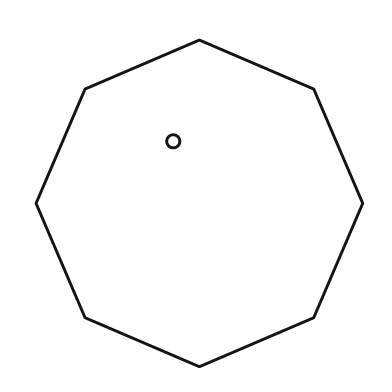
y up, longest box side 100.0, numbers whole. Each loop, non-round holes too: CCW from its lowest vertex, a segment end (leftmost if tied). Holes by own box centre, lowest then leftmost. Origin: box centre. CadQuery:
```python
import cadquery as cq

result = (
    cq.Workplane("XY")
    .moveTo(0.0, -50.0)
    .lineTo(35.0, -35.0)
    .lineTo(50.0, 0.0)
    .lineTo(35.0, 35.0)
    .lineTo(0.0, 50.0)
    .lineTo(-35.0, 35.0)
    .lineTo(-50.0, 0.0)
    .lineTo(-35.0, -35.0)
    .close()
    .moveTo(-8.0, 19.0)
    .circle(2.0)
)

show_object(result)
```